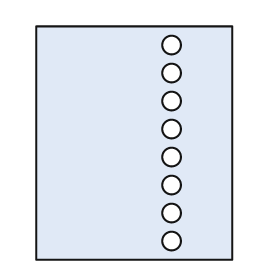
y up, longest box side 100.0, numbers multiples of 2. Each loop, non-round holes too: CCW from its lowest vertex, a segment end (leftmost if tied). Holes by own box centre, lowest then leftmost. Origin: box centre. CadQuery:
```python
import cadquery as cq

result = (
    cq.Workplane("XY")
    .moveTo(-42.0, -50.0)
    .lineTo(42.0, -50.0)
    .lineTo(42.0, 50.0)
    .lineTo(-42.0, 50.0)
    .close()
    .moveTo(16.0, -42.0)
    .circle(4.0)
    .moveTo(16.0, -30.0)
    .circle(4.0)
    .moveTo(16.0, -18.0)
    .circle(4.0)
    .moveTo(16.0, -6.0)
    .circle(4.0)
    .moveTo(16.0, 6.0)
    .circle(4.0)
    .moveTo(16.0, 18.0)
    .circle(4.0)
    .moveTo(16.0, 30.0)
    .circle(4.0)
    .moveTo(16.0, 42.0)
    .circle(4.0)
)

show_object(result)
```